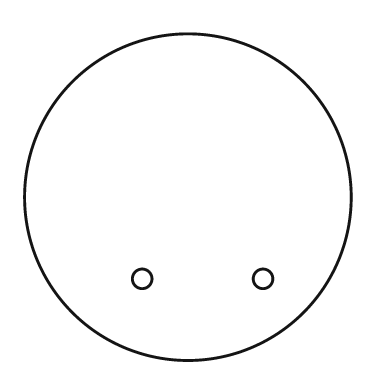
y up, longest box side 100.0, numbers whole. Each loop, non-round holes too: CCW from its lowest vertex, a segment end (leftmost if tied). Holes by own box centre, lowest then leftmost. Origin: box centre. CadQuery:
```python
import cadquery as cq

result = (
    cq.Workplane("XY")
    .moveTo(0.0, 0.0)
    .circle(50.0)
    .moveTo(-14.0, -25.0)
    .circle(3.0)
    .moveTo(23.0, -25.0)
    .circle(3.0)
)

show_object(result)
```